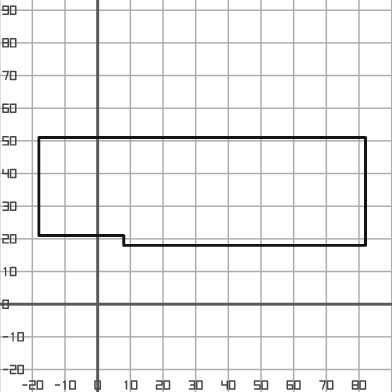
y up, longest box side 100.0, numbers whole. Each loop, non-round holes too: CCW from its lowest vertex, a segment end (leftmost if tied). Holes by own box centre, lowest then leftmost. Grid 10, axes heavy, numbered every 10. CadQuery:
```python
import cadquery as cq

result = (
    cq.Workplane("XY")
    .moveTo(8.0, 18.0)
    .lineTo(82.0, 18.0)
    .lineTo(82.0, 51.0)
    .lineTo(-18.0, 51.0)
    .lineTo(-18.0, 21.0)
    .lineTo(8.0, 21.0)
    .close()
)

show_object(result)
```